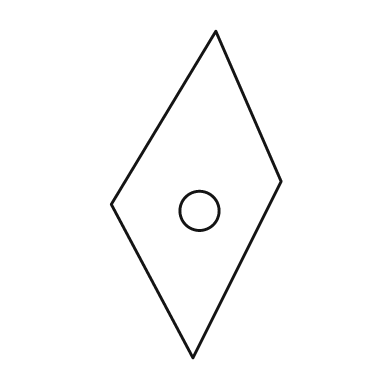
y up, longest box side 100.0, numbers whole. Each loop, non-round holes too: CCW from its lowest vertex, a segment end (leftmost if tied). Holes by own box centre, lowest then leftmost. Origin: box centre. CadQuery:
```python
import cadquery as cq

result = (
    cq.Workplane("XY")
    .moveTo(-1.0, -50.0)
    .lineTo(26.0, 4.0)
    .lineTo(6.0, 50.0)
    .lineTo(-26.0, -3.0)
    .close()
    .moveTo(1.0, -5.0)
    .circle(6.0)
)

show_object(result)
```